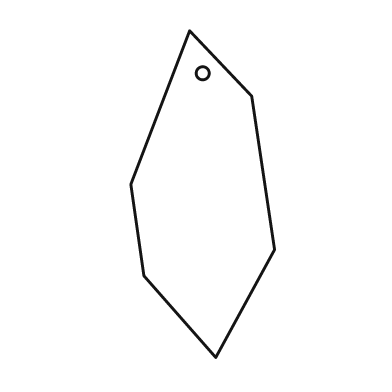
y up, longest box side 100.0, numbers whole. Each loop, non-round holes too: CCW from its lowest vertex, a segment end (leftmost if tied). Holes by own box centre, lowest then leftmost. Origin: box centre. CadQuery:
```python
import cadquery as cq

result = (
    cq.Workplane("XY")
    .moveTo(4.0, -50.0)
    .lineTo(22.0, -17.0)
    .lineTo(15.0, 30.0)
    .lineTo(-4.0, 50.0)
    .lineTo(-22.0, 3.0)
    .lineTo(-18.0, -25.0)
    .close()
    .moveTo(0.0, 37.0)
    .circle(2.0)
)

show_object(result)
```